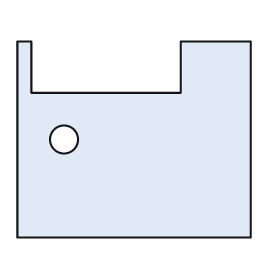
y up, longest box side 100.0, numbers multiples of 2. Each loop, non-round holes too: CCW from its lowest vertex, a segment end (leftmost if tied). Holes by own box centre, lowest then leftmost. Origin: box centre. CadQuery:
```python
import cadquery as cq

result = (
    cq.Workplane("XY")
    .moveTo(-50.0, -42.0)
    .lineTo(50.0, -42.0)
    .lineTo(50.0, 42.0)
    .lineTo(20.0, 42.0)
    .lineTo(20.0, 20.0)
    .lineTo(-44.0, 20.0)
    .lineTo(-44.0, 42.0)
    .lineTo(-50.0, 42.0)
    .close()
    .moveTo(-30.0, 0.0)
    .circle(6.0)
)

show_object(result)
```